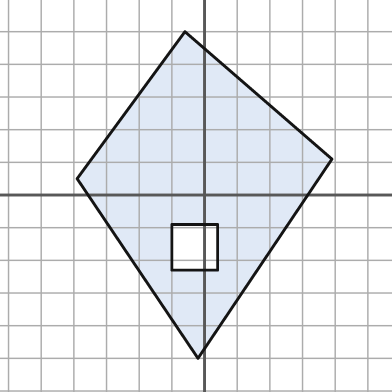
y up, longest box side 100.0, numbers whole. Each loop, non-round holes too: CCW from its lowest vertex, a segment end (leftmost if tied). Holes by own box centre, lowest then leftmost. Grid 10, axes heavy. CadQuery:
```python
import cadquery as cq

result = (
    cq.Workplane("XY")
    .moveTo(-2.0, -50.0)
    .lineTo(39.0, 11.0)
    .lineTo(-6.0, 50.0)
    .lineTo(-39.0, 5.0)
    .close()
    .moveTo(-10.0, -23.0)
    .lineTo(4.0, -23.0)
    .lineTo(4.0, -9.0)
    .lineTo(-10.0, -9.0)
    .close()
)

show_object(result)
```